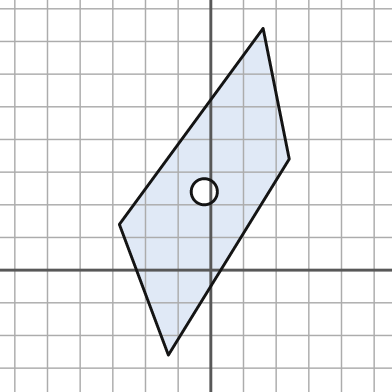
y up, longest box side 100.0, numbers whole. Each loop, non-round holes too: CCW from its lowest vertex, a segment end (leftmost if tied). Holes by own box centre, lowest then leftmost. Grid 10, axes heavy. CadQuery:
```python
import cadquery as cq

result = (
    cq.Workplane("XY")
    .moveTo(-13.0, -26.0)
    .lineTo(24.0, 34.0)
    .lineTo(16.0, 74.0)
    .lineTo(-28.0, 14.0)
    .close()
    .moveTo(-2.0, 24.0)
    .circle(4.0)
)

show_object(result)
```